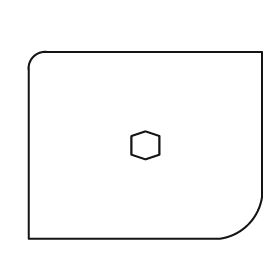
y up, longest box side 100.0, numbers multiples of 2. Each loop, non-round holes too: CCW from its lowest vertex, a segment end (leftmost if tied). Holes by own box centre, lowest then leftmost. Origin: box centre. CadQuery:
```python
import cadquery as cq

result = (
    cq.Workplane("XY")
    .moveTo(-50.0, -40.0)
    .lineTo(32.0, -40.0)
    .threePointArc((44.0, -34.0), (50.0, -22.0))
    .lineTo(50.0, 40.0)
    .lineTo(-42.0, 40.0)
    .threePointArc((-48.0, 38.0), (-50.0, 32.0))
    .close()
    .moveTo(0.0, -6.0)
    .lineTo(6.0, -4.0)
    .lineTo(6.0, 4.0)
    .lineTo(0.0, 6.0)
    .lineTo(-6.0, 4.0)
    .lineTo(-6.0, -4.0)
    .close()
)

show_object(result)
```